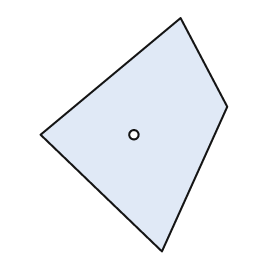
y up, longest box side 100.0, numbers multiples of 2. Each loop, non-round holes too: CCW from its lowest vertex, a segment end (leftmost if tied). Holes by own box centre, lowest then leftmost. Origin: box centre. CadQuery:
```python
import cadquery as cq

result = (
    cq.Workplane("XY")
    .moveTo(12.0, -50.0)
    .lineTo(40.0, 12.0)
    .lineTo(20.0, 50.0)
    .lineTo(-40.0, 0.0)
    .close()
    .moveTo(0.0, 0.0)
    .circle(2.0)
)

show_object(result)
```